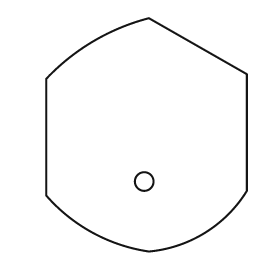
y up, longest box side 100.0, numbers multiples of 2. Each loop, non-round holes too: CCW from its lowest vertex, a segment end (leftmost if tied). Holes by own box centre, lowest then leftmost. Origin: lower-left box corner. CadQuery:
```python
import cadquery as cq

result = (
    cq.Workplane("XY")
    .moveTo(44.0, 0.0)
    .threePointArc((68.0, 8.0), (86.0, 26.0))
    .lineTo(86.0, 76.0)
    .lineTo(44.0, 100.0)
    .threePointArc((20.0, 90.0), (0.0, 74.0))
    .lineTo(0.0, 24.0)
    .threePointArc((20.0, 8.0), (44.0, 0.0))
    .close()
    .moveTo(42.0, 30.0)
    .circle(4.0)
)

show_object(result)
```